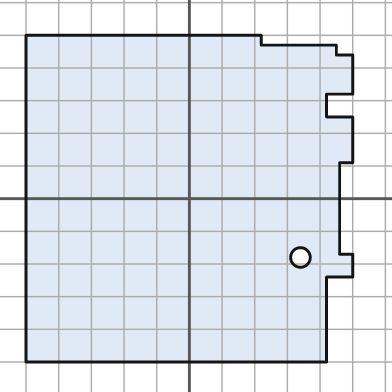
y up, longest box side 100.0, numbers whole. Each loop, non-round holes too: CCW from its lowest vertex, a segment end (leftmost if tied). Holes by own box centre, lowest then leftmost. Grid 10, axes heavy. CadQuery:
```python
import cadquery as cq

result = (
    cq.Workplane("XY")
    .moveTo(-50.0, -50.0)
    .lineTo(42.0, -50.0)
    .lineTo(42.0, -24.0)
    .lineTo(50.0, -24.0)
    .lineTo(50.0, -17.0)
    .lineTo(46.0, -17.0)
    .lineTo(46.0, 11.0)
    .lineTo(50.0, 11.0)
    .lineTo(50.0, 25.0)
    .lineTo(42.0, 25.0)
    .lineTo(42.0, 32.0)
    .lineTo(50.0, 32.0)
    .lineTo(50.0, 44.0)
    .lineTo(45.0, 44.0)
    .lineTo(45.0, 47.0)
    .lineTo(22.0, 47.0)
    .lineTo(22.0, 50.0)
    .lineTo(-50.0, 50.0)
    .close()
    .moveTo(34.0, -18.0)
    .circle(3.0)
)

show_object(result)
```